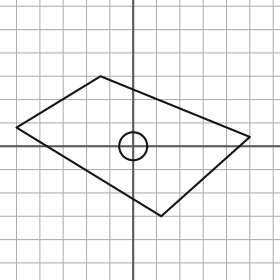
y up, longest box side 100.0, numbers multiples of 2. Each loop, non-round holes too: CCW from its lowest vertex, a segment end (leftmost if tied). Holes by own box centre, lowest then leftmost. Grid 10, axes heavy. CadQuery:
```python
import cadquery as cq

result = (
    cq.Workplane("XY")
    .moveTo(12.0, -30.0)
    .lineTo(50.0, 4.0)
    .lineTo(-14.0, 30.0)
    .lineTo(-50.0, 8.0)
    .close()
    .moveTo(0.0, 0.0)
    .circle(6.0)
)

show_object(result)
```